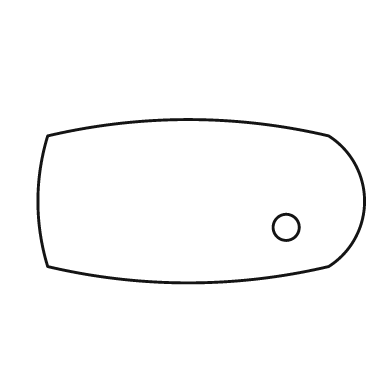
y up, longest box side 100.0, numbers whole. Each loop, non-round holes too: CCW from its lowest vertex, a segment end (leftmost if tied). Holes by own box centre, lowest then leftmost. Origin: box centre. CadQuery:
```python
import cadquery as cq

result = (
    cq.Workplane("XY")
    .moveTo(-47.0, -20.0)
    .threePointArc((-4.0, -25.0), (39.0, -20.0))
    .threePointArc((50.0, 0.0), (39.0, 20.0))
    .threePointArc((-4.0, 25.0), (-47.0, 20.0))
    .threePointArc((-50.0, 0.0), (-47.0, -20.0))
    .close()
    .moveTo(26.0, -8.0)
    .circle(4.0)
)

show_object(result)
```